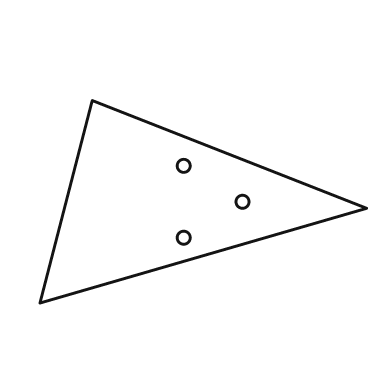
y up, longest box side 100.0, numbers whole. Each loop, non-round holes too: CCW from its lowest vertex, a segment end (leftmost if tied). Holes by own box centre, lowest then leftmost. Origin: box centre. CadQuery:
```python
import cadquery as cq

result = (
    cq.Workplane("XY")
    .moveTo(-50.0, -31.0)
    .lineTo(50.0, -2.0)
    .lineTo(-34.0, 31.0)
    .close()
    .moveTo(-6.0, -11.0)
    .circle(2.0)
    .moveTo(12.0, 0.0)
    .circle(2.0)
    .moveTo(-6.0, 11.0)
    .circle(2.0)
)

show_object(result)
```